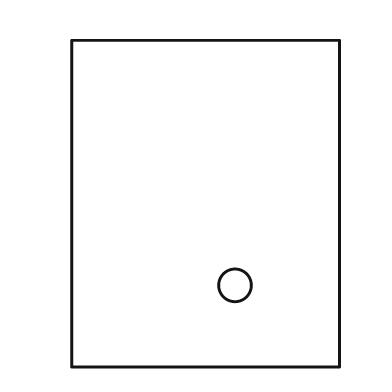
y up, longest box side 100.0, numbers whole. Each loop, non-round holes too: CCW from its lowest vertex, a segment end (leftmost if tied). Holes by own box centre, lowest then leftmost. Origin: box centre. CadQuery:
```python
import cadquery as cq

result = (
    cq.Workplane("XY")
    .moveTo(-41.0, -50.0)
    .lineTo(41.0, -50.0)
    .lineTo(41.0, 50.0)
    .lineTo(-41.0, 50.0)
    .close()
    .moveTo(9.0, -25.0)
    .circle(5.0)
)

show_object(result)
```